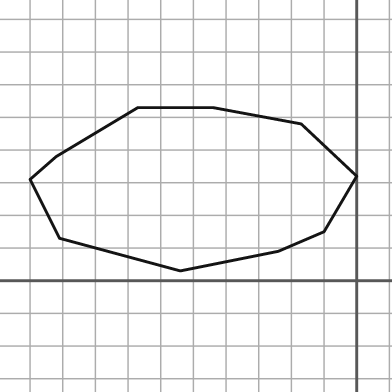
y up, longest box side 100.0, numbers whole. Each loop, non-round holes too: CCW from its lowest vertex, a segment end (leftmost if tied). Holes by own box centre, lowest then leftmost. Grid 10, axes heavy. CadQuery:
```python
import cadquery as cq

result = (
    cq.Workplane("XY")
    .moveTo(-54.0, 3.0)
    .lineTo(-24.0, 9.0)
    .lineTo(-10.0, 15.0)
    .lineTo(0.0, 32.0)
    .lineTo(-17.0, 48.0)
    .lineTo(-44.0, 53.0)
    .lineTo(-67.0, 53.0)
    .lineTo(-92.0, 38.0)
    .lineTo(-100.0, 31.0)
    .lineTo(-91.0, 13.0)
    .close()
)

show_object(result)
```